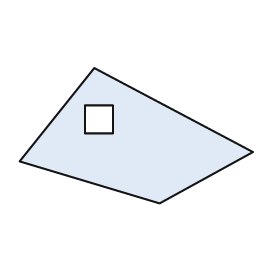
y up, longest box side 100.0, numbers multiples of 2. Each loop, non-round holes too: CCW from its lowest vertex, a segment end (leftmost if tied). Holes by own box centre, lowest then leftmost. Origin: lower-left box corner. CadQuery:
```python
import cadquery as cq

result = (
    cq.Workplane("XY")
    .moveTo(60.0, 0.0)
    .lineTo(100.0, 22.0)
    .lineTo(32.0, 58.0)
    .lineTo(0.0, 18.0)
    .close()
    .moveTo(28.0, 30.0)
    .lineTo(40.0, 30.0)
    .lineTo(40.0, 42.0)
    .lineTo(28.0, 42.0)
    .close()
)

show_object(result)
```